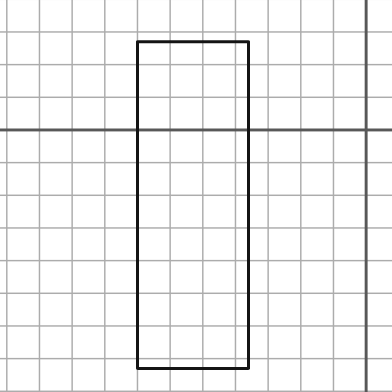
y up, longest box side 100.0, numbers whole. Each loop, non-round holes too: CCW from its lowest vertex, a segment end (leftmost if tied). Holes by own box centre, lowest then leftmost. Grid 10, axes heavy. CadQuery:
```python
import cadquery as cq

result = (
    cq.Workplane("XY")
    .moveTo(-70.0, -73.0)
    .lineTo(-36.0, -73.0)
    .lineTo(-36.0, 27.0)
    .lineTo(-70.0, 27.0)
    .close()
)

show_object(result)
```